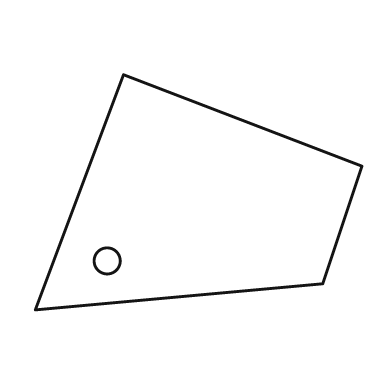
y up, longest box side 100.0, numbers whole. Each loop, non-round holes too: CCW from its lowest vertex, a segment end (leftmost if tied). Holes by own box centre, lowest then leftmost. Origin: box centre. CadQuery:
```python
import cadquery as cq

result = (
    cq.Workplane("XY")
    .moveTo(-50.0, -36.0)
    .lineTo(38.0, -28.0)
    .lineTo(50.0, 8.0)
    .lineTo(-23.0, 36.0)
    .close()
    .moveTo(-28.0, -21.0)
    .circle(4.0)
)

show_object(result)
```